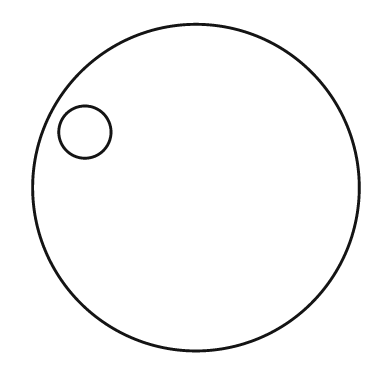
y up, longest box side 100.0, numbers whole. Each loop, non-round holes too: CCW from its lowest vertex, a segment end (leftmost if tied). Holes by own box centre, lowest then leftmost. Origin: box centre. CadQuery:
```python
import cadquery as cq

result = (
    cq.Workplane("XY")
    .moveTo(0.0, 0.0)
    .circle(50.0)
    .moveTo(-34.0, 17.0)
    .circle(8.0)
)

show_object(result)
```